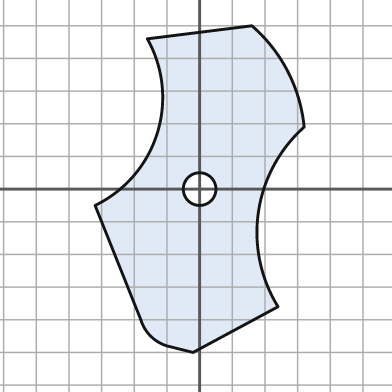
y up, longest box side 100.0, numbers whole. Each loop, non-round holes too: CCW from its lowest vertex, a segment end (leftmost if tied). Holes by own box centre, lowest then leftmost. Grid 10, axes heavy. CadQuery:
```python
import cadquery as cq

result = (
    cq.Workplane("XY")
    .moveTo(-2.0, -50.0)
    .lineTo(24.0, -36.0)
    .threePointArc((18.0, -7.0), (32.0, 19.0))
    .threePointArc((27.0, 36.0), (16.0, 50.0))
    .lineTo(-16.0, 46.0)
    .threePointArc((-13.0, 17.0), (-32.0, -5.0))
    .lineTo(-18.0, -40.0)
    .threePointArc((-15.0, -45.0), (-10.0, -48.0))
    .close()
    .moveTo(0.0, 0.0)
    .circle(5.0)
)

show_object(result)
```